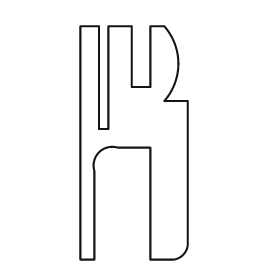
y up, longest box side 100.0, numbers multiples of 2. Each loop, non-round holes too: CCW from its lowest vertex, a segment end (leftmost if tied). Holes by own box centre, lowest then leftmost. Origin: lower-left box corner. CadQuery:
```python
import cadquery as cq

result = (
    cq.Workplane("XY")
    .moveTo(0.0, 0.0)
    .lineTo(6.0, 0.0)
    .lineTo(6.0, 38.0)
    .threePointArc((8.0, 46.0), (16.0, 48.0))
    .lineTo(30.0, 48.0)
    .lineTo(30.0, 0.0)
    .lineTo(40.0, 0.0)
    .threePointArc((44.0, 2.0), (46.0, 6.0))
    .lineTo(46.0, 68.0)
    .lineTo(36.0, 68.0)
    .threePointArc((42.0, 84.0), (36.0, 100.0))
    .lineTo(30.0, 100.0)
    .lineTo(30.0, 74.0)
    .lineTo(22.0, 74.0)
    .lineTo(22.0, 100.0)
    .lineTo(12.0, 100.0)
    .lineTo(12.0, 56.0)
    .lineTo(8.0, 56.0)
    .lineTo(8.0, 100.0)
    .lineTo(0.0, 100.0)
    .close()
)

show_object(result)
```